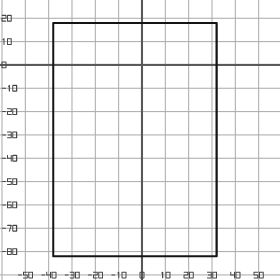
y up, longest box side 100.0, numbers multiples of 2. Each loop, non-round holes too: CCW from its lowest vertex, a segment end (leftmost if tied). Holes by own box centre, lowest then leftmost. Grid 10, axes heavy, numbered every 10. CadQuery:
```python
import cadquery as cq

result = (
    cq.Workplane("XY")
    .moveTo(-38.0, -82.0)
    .lineTo(32.0, -82.0)
    .lineTo(32.0, 18.0)
    .lineTo(-38.0, 18.0)
    .close()
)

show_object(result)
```